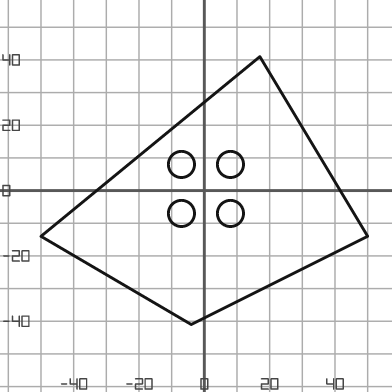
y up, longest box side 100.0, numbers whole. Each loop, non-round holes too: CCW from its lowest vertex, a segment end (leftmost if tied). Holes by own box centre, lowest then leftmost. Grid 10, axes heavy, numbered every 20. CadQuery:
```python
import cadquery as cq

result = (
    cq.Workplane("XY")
    .moveTo(-4.0, -41.0)
    .lineTo(50.0, -14.0)
    .lineTo(17.0, 41.0)
    .lineTo(-50.0, -14.0)
    .close()
    .moveTo(-7.0, -7.0)
    .circle(4.0)
    .moveTo(8.0, -7.0)
    .circle(4.0)
    .moveTo(-7.0, 8.0)
    .circle(4.0)
    .moveTo(8.0, 8.0)
    .circle(4.0)
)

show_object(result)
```